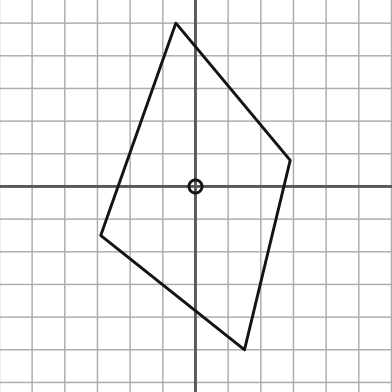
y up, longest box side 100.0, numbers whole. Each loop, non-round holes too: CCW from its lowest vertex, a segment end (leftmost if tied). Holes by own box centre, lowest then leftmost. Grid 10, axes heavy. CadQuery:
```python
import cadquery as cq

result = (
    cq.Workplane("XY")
    .moveTo(15.0, -50.0)
    .lineTo(29.0, 8.0)
    .lineTo(-6.0, 50.0)
    .lineTo(-29.0, -15.0)
    .close()
    .moveTo(0.0, 0.0)
    .circle(2.0)
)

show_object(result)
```